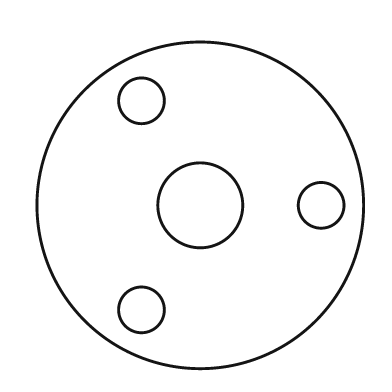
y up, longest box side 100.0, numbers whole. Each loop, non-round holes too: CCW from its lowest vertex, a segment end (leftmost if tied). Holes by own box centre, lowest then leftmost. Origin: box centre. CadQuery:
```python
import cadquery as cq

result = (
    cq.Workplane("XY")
    .moveTo(0.0, 0.0)
    .circle(50.0)
    .moveTo(-18.0, -32.0)
    .circle(7.0)
    .moveTo(0.0, 0.0)
    .circle(13.0)
    .moveTo(37.0, 0.0)
    .circle(7.0)
    .moveTo(-18.0, 32.0)
    .circle(7.0)
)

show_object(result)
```